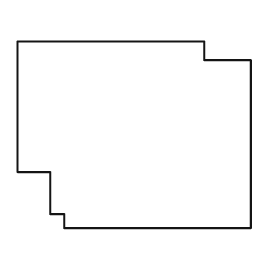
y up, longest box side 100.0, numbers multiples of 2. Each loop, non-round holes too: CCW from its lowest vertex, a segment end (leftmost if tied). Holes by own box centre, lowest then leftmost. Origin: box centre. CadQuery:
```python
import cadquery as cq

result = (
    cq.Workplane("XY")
    .moveTo(-30.0, -40.0)
    .lineTo(50.0, -40.0)
    .lineTo(50.0, 32.0)
    .lineTo(30.0, 32.0)
    .lineTo(30.0, 40.0)
    .lineTo(-50.0, 40.0)
    .lineTo(-50.0, -16.0)
    .lineTo(-36.0, -16.0)
    .lineTo(-36.0, -34.0)
    .lineTo(-30.0, -34.0)
    .close()
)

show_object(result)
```